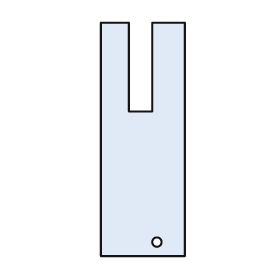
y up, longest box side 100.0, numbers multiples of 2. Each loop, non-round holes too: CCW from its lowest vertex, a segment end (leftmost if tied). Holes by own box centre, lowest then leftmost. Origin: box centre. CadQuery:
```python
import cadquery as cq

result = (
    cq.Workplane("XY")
    .moveTo(-18.0, -50.0)
    .lineTo(18.0, -50.0)
    .lineTo(18.0, 50.0)
    .lineTo(4.0, 50.0)
    .lineTo(4.0, 12.0)
    .lineTo(-6.0, 12.0)
    .lineTo(-6.0, 50.0)
    .lineTo(-18.0, 50.0)
    .close()
    .moveTo(6.0, -44.0)
    .circle(2.0)
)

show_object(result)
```